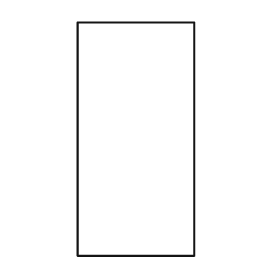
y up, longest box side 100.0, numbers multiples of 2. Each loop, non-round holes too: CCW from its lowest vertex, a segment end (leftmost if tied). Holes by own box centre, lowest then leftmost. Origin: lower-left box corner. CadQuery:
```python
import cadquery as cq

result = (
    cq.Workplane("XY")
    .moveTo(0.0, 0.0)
    .lineTo(50.0, 0.0)
    .lineTo(50.0, 100.0)
    .lineTo(0.0, 100.0)
    .close()
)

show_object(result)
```